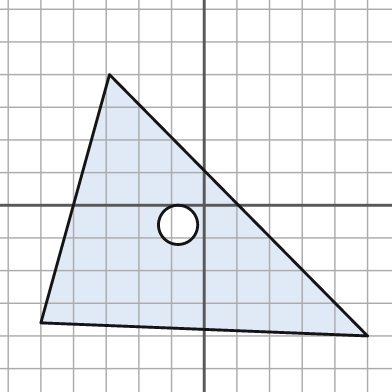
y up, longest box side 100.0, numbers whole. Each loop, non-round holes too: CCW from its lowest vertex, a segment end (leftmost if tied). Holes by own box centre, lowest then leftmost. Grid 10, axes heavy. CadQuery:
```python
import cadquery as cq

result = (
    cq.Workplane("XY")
    .moveTo(50.0, -40.0)
    .lineTo(-29.0, 40.0)
    .lineTo(-50.0, -36.0)
    .close()
    .moveTo(-8.0, -6.0)
    .circle(6.0)
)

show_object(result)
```